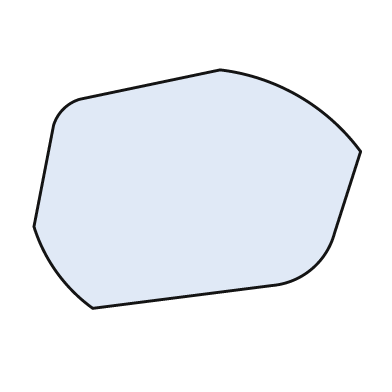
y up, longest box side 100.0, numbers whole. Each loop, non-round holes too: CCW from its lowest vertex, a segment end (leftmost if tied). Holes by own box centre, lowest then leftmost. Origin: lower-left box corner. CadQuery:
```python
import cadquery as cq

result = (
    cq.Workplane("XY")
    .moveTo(18.0, 0.0)
    .lineTo(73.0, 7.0)
    .threePointArc((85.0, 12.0), (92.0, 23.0))
    .lineTo(100.0, 48.0)
    .threePointArc((81.0, 65.0), (57.0, 73.0))
    .lineTo(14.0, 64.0)
    .threePointArc((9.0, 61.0), (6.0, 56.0))
    .lineTo(0.0, 25.0)
    .threePointArc((7.0, 11.0), (18.0, 0.0))
    .close()
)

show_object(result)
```